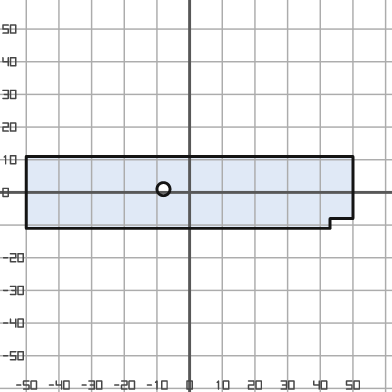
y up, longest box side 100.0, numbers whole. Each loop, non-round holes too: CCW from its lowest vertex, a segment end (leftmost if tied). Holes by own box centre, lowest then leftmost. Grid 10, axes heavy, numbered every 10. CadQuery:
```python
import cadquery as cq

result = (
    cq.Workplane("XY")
    .moveTo(-50.0, -11.0)
    .lineTo(43.0, -11.0)
    .lineTo(43.0, -8.0)
    .lineTo(50.0, -8.0)
    .lineTo(50.0, 11.0)
    .lineTo(-50.0, 11.0)
    .close()
    .moveTo(-8.0, 1.0)
    .circle(2.0)
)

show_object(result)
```